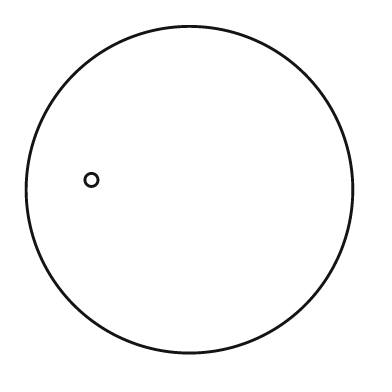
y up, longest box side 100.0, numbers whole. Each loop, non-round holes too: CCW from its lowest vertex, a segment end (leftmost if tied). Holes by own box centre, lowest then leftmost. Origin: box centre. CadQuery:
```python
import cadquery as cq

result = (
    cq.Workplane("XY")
    .moveTo(0.0, 0.0)
    .circle(50.0)
    .moveTo(-30.0, 3.0)
    .circle(2.0)
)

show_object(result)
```